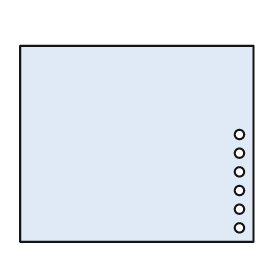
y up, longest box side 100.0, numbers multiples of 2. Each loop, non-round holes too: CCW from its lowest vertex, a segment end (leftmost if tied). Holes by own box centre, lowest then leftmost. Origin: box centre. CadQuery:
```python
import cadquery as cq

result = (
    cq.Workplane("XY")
    .moveTo(-50.0, -42.0)
    .lineTo(50.0, -42.0)
    .lineTo(50.0, 42.0)
    .lineTo(-50.0, 42.0)
    .close()
    .moveTo(44.0, -36.0)
    .circle(2.0)
    .moveTo(44.0, -28.0)
    .circle(2.0)
    .moveTo(44.0, -20.0)
    .circle(2.0)
    .moveTo(44.0, -12.0)
    .circle(2.0)
    .moveTo(44.0, -4.0)
    .circle(2.0)
    .moveTo(44.0, 4.0)
    .circle(2.0)
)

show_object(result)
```